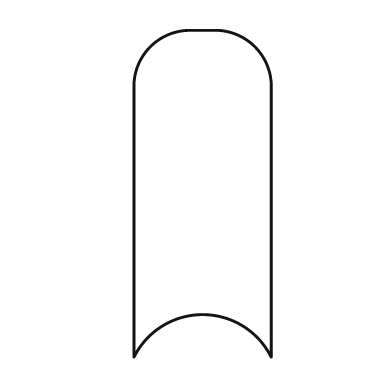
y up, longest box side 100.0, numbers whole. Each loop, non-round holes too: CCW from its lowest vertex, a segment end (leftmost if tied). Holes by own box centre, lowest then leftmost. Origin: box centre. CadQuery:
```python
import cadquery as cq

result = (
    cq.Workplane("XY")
    .moveTo(-21.0, -50.0)
    .threePointArc((0.0, -37.0), (21.0, -50.0))
    .lineTo(21.0, 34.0)
    .threePointArc((16.0, 45.0), (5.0, 50.0))
    .lineTo(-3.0, 50.0)
    .threePointArc((-16.0, 45.0), (-21.0, 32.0))
    .close()
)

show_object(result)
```